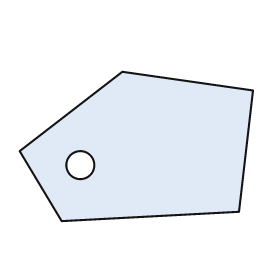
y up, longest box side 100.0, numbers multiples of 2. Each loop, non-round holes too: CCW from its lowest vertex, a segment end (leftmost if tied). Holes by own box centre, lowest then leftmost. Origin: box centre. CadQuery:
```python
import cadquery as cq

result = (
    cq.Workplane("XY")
    .moveTo(-32.0, -32.0)
    .lineTo(44.0, -28.0)
    .lineTo(50.0, 24.0)
    .lineTo(-6.0, 32.0)
    .lineTo(-50.0, -2.0)
    .close()
    .moveTo(-24.0, -8.0)
    .circle(6.0)
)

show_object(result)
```